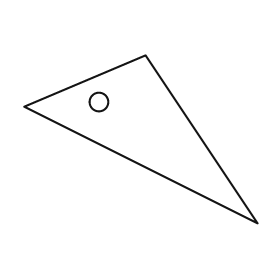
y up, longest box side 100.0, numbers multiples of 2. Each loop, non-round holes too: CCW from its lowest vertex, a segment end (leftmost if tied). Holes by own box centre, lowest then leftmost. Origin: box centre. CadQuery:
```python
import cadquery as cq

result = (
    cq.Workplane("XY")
    .moveTo(50.0, -36.0)
    .lineTo(2.0, 36.0)
    .lineTo(-50.0, 14.0)
    .close()
    .moveTo(-18.0, 16.0)
    .circle(4.0)
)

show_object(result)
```